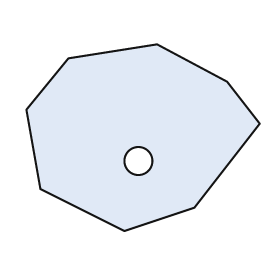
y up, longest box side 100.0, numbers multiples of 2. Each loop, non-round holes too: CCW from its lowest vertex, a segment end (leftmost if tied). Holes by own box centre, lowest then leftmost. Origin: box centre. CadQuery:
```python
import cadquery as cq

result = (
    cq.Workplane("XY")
    .moveTo(-8.0, -40.0)
    .lineTo(22.0, -30.0)
    .lineTo(50.0, 6.0)
    .lineTo(36.0, 24.0)
    .lineTo(6.0, 40.0)
    .lineTo(-32.0, 34.0)
    .lineTo(-50.0, 12.0)
    .lineTo(-44.0, -22.0)
    .close()
    .moveTo(-2.0, -10.0)
    .circle(6.0)
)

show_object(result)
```